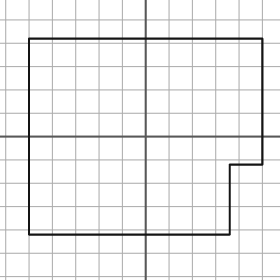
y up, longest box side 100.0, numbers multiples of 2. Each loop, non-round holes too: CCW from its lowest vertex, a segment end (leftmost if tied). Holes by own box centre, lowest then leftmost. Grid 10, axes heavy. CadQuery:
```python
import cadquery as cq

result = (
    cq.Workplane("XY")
    .moveTo(-50.0, -42.0)
    .lineTo(36.0, -42.0)
    .lineTo(36.0, -12.0)
    .lineTo(50.0, -12.0)
    .lineTo(50.0, 42.0)
    .lineTo(-50.0, 42.0)
    .close()
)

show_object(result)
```